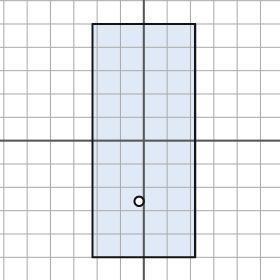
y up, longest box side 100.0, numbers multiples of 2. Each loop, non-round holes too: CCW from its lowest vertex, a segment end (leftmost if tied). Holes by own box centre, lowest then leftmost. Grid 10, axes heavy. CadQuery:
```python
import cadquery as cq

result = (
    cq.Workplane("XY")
    .moveTo(-22.0, -50.0)
    .lineTo(22.0, -50.0)
    .lineTo(22.0, 50.0)
    .lineTo(-22.0, 50.0)
    .close()
    .moveTo(-2.0, -26.0)
    .circle(2.0)
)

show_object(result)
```